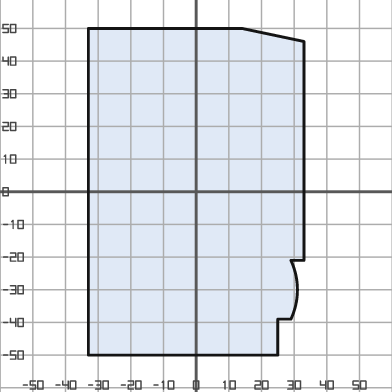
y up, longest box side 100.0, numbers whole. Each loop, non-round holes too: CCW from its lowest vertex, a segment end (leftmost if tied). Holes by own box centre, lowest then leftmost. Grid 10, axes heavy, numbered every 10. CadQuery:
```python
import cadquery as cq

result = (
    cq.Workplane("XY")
    .moveTo(-33.0, -50.0)
    .lineTo(25.0, -50.0)
    .lineTo(25.0, -39.0)
    .lineTo(29.0, -39.0)
    .threePointArc((31.0, -30.0), (29.0, -21.0))
    .lineTo(33.0, -21.0)
    .lineTo(33.0, 46.0)
    .lineTo(14.0, 50.0)
    .lineTo(-33.0, 50.0)
    .close()
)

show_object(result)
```